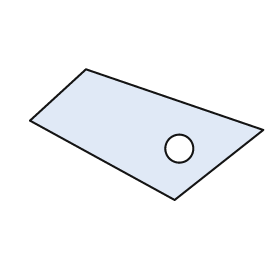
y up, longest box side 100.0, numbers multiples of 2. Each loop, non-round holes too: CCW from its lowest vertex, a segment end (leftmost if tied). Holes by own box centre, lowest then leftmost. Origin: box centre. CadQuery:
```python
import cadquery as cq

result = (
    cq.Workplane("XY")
    .moveTo(12.0, -28.0)
    .lineTo(50.0, 2.0)
    .lineTo(-26.0, 28.0)
    .lineTo(-50.0, 6.0)
    .close()
    .moveTo(14.0, -6.0)
    .circle(6.0)
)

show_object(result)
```